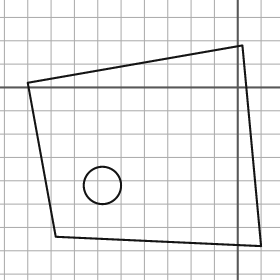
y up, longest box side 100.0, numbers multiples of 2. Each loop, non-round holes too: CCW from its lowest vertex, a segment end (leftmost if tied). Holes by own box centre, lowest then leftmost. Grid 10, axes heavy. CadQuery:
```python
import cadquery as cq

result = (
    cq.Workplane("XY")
    .moveTo(10.0, -68.0)
    .lineTo(2.0, 18.0)
    .lineTo(-90.0, 2.0)
    .lineTo(-78.0, -64.0)
    .close()
    .moveTo(-58.0, -42.0)
    .circle(8.0)
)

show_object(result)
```